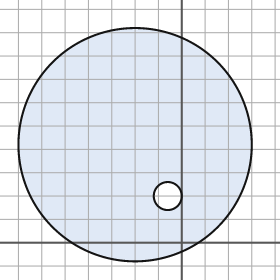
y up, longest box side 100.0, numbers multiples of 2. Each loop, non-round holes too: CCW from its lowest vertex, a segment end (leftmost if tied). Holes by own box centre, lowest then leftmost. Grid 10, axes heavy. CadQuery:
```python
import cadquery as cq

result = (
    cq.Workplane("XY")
    .moveTo(-20.0, 42.0)
    .circle(50.0)
    .moveTo(-6.0, 20.0)
    .circle(6.0)
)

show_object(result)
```